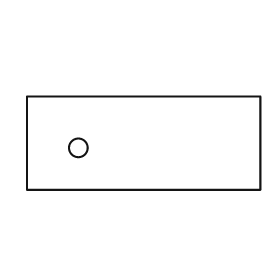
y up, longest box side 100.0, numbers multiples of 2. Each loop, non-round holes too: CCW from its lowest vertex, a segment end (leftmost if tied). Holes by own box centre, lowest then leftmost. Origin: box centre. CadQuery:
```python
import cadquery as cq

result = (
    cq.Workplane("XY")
    .moveTo(-50.0, -20.0)
    .lineTo(50.0, -20.0)
    .lineTo(50.0, 20.0)
    .lineTo(-50.0, 20.0)
    .close()
    .moveTo(-28.0, -2.0)
    .circle(4.0)
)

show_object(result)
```